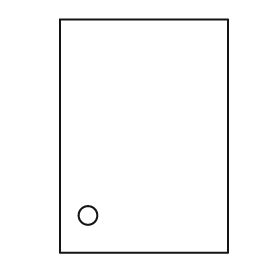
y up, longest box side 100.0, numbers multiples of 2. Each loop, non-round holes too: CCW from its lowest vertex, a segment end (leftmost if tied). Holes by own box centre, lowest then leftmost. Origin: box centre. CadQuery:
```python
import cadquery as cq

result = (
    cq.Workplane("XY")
    .moveTo(-36.0, -50.0)
    .lineTo(36.0, -50.0)
    .lineTo(36.0, 50.0)
    .lineTo(-36.0, 50.0)
    .close()
    .moveTo(-24.0, -34.0)
    .circle(4.0)
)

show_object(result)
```